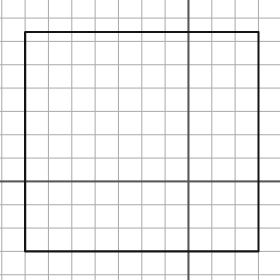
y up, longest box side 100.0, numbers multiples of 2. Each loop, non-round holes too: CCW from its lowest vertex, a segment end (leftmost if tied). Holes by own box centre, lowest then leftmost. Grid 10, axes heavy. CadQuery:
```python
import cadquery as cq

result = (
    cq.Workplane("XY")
    .moveTo(-70.0, -30.0)
    .lineTo(30.0, -30.0)
    .lineTo(30.0, 64.0)
    .lineTo(-70.0, 64.0)
    .close()
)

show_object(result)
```